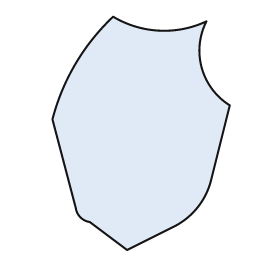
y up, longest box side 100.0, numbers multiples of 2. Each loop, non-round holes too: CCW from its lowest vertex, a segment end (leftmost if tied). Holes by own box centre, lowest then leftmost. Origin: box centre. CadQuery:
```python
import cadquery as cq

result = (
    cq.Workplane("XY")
    .moveTo(-6.0, -50.0)
    .lineTo(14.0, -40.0)
    .threePointArc((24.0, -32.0), (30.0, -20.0))
    .lineTo(38.0, 12.0)
    .threePointArc((26.0, 28.0), (28.0, 48.0))
    .threePointArc((8.0, 44.0), (-12.0, 50.0))
    .threePointArc((-28.0, 30.0), (-38.0, 6.0))
    .lineTo(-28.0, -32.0)
    .threePointArc((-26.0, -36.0), (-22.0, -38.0))
    .close()
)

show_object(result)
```